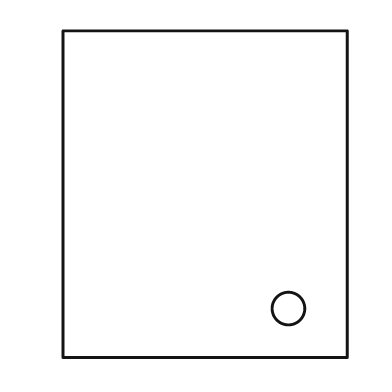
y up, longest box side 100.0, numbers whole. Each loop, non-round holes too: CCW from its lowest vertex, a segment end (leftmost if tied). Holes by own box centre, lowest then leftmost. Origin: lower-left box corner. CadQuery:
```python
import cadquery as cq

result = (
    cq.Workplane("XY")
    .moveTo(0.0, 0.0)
    .lineTo(87.0, 0.0)
    .lineTo(87.0, 100.0)
    .lineTo(0.0, 100.0)
    .close()
    .moveTo(69.0, 15.0)
    .circle(5.0)
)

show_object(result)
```